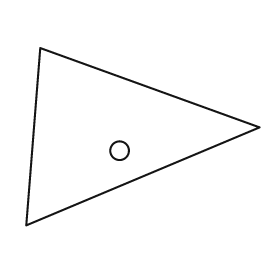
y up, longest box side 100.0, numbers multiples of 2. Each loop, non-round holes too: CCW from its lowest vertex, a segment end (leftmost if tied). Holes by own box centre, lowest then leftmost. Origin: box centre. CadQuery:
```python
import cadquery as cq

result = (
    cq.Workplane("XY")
    .moveTo(-50.0, -38.0)
    .lineTo(50.0, 4.0)
    .lineTo(-44.0, 38.0)
    .close()
    .moveTo(-10.0, -6.0)
    .circle(4.0)
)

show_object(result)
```